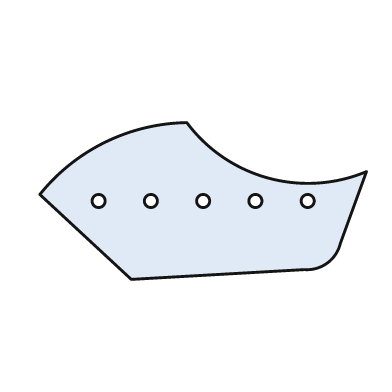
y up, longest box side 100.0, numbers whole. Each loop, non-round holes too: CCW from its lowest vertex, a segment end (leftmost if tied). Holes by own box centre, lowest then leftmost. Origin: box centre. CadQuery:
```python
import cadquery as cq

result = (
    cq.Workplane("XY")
    .moveTo(-22.0, -24.0)
    .lineTo(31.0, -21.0)
    .threePointArc((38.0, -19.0), (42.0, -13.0))
    .lineTo(50.0, 9.0)
    .threePointArc((20.0, 7.0), (-5.0, 24.0))
    .threePointArc((-30.0, 18.0), (-50.0, 2.0))
    .close()
    .moveTo(-32.0, 0.0)
    .circle(2.0)
    .moveTo(-16.0, 0.0)
    .circle(2.0)
    .moveTo(0.0, 0.0)
    .circle(2.0)
    .moveTo(16.0, 0.0)
    .circle(2.0)
    .moveTo(32.0, 0.0)
    .circle(2.0)
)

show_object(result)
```